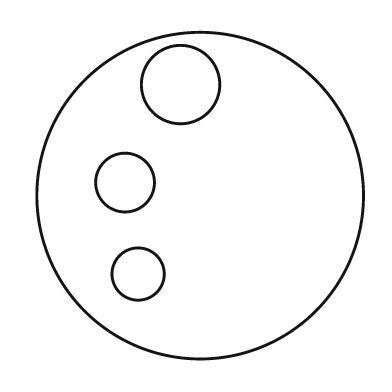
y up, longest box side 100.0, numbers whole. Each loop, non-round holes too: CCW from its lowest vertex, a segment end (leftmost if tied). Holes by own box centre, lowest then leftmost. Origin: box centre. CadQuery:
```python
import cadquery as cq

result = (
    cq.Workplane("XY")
    .moveTo(0.0, 0.0)
    .circle(50.0)
    .moveTo(-19.0, -24.0)
    .circle(8.0)
    .moveTo(-23.0, 4.0)
    .circle(9.0)
    .moveTo(-6.0, 34.0)
    .circle(12.0)
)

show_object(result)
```